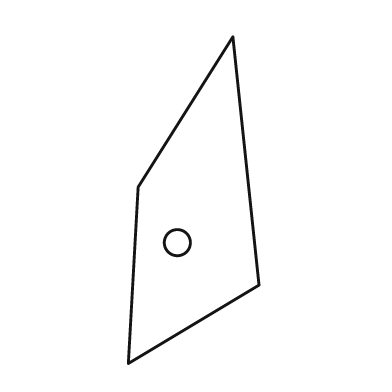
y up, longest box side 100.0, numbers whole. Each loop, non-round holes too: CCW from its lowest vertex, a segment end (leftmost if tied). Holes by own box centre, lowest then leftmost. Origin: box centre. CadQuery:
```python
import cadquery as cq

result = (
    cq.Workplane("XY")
    .moveTo(-20.0, -50.0)
    .lineTo(20.0, -26.0)
    .lineTo(12.0, 50.0)
    .lineTo(-17.0, 4.0)
    .close()
    .moveTo(-5.0, -13.0)
    .circle(4.0)
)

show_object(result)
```